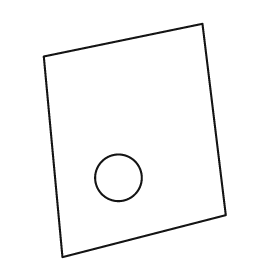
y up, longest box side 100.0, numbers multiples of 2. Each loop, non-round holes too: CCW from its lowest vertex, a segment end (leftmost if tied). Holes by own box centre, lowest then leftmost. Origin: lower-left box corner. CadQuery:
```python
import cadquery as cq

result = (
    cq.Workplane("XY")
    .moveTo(8.0, 0.0)
    .lineTo(78.0, 18.0)
    .lineTo(68.0, 100.0)
    .lineTo(0.0, 86.0)
    .close()
    .moveTo(32.0, 34.0)
    .circle(10.0)
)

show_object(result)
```